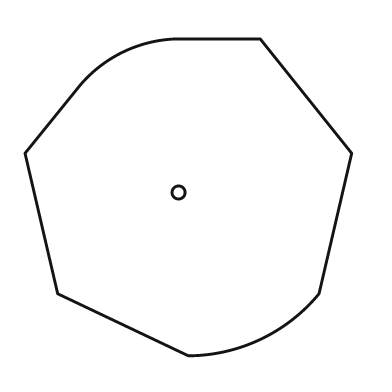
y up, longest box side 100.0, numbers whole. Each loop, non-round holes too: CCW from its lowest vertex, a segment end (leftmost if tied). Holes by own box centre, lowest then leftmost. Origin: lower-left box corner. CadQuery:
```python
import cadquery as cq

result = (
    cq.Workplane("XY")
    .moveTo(50.0, 0.0)
    .threePointArc((72.0, 5.0), (90.0, 19.0))
    .lineTo(100.0, 62.0)
    .lineTo(72.0, 97.0)
    .lineTo(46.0, 97.0)
    .threePointArc((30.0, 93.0), (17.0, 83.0))
    .lineTo(0.0, 62.0)
    .lineTo(10.0, 19.0)
    .close()
    .moveTo(47.0, 50.0)
    .circle(2.0)
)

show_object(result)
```